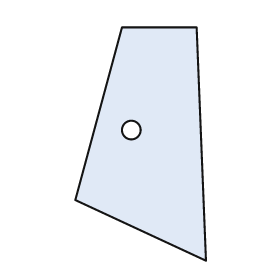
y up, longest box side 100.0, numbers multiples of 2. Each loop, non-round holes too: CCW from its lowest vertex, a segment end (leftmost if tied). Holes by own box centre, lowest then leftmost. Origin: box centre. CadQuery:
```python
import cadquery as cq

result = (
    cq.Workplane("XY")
    .moveTo(28.0, -50.0)
    .lineTo(24.0, 50.0)
    .lineTo(-8.0, 50.0)
    .lineTo(-28.0, -24.0)
    .close()
    .moveTo(-4.0, 6.0)
    .circle(4.0)
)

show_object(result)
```